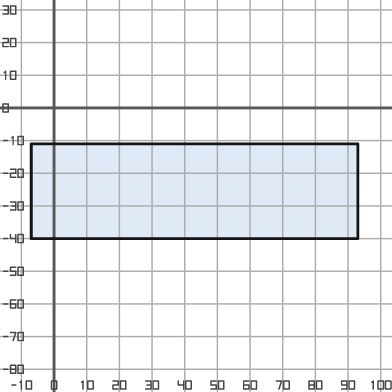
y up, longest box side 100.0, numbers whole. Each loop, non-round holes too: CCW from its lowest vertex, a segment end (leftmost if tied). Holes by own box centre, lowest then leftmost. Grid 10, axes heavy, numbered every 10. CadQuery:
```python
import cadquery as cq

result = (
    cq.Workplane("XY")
    .moveTo(-7.0, -40.0)
    .lineTo(93.0, -40.0)
    .lineTo(93.0, -11.0)
    .lineTo(-7.0, -11.0)
    .close()
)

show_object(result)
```